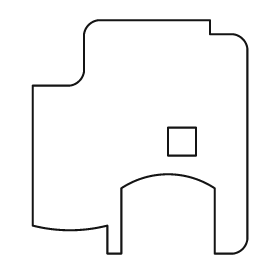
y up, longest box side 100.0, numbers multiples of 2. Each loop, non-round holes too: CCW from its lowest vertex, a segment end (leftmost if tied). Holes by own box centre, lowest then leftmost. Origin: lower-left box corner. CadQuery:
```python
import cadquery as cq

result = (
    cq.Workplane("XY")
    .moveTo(32.0, 0.0)
    .lineTo(38.0, 0.0)
    .lineTo(38.0, 28.0)
    .threePointArc((58.0, 34.0), (78.0, 28.0))
    .lineTo(78.0, 0.0)
    .lineTo(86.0, 0.0)
    .threePointArc((90.0, 2.0), (92.0, 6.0))
    .lineTo(92.0, 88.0)
    .threePointArc((90.0, 92.0), (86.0, 94.0))
    .lineTo(76.0, 94.0)
    .lineTo(76.0, 100.0)
    .lineTo(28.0, 100.0)
    .threePointArc((24.0, 98.0), (22.0, 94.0))
    .lineTo(22.0, 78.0)
    .threePointArc((20.0, 74.0), (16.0, 72.0))
    .lineTo(0.0, 72.0)
    .lineTo(0.0, 12.0)
    .threePointArc((16.0, 10.0), (32.0, 12.0))
    .close()
    .moveTo(58.0, 42.0)
    .lineTo(70.0, 42.0)
    .lineTo(70.0, 54.0)
    .lineTo(58.0, 54.0)
    .close()
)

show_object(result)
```